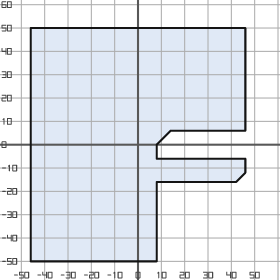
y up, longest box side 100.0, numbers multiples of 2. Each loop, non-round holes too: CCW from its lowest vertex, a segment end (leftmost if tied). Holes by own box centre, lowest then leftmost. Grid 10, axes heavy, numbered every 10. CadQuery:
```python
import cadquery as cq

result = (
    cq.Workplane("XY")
    .moveTo(-46.0, -50.0)
    .lineTo(8.0, -50.0)
    .lineTo(8.0, -16.0)
    .lineTo(42.0, -16.0)
    .lineTo(46.0, -12.0)
    .lineTo(46.0, -6.0)
    .lineTo(8.0, -6.0)
    .lineTo(8.0, 0.0)
    .lineTo(14.0, 6.0)
    .lineTo(46.0, 6.0)
    .lineTo(46.0, 50.0)
    .lineTo(-46.0, 50.0)
    .close()
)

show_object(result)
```